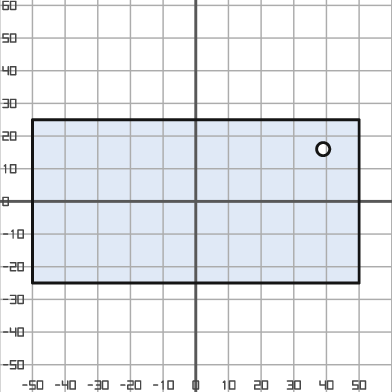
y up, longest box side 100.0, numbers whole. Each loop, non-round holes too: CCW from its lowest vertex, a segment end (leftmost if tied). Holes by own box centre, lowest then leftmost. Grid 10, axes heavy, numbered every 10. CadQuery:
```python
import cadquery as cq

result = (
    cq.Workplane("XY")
    .moveTo(-50.0, -25.0)
    .lineTo(50.0, -25.0)
    .lineTo(50.0, 25.0)
    .lineTo(-50.0, 25.0)
    .close()
    .moveTo(39.0, 16.0)
    .circle(2.0)
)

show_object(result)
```